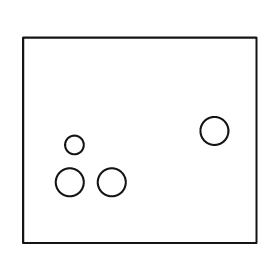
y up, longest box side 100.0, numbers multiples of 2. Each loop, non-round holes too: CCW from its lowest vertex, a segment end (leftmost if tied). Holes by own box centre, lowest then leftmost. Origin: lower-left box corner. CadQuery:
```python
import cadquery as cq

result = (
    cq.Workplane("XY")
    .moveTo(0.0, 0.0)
    .lineTo(100.0, 0.0)
    .lineTo(100.0, 88.0)
    .lineTo(0.0, 88.0)
    .close()
    .moveTo(20.0, 26.0)
    .circle(6.0)
    .moveTo(38.0, 26.0)
    .circle(6.0)
    .moveTo(22.0, 42.0)
    .circle(4.0)
    .moveTo(82.0, 48.0)
    .circle(6.0)
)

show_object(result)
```